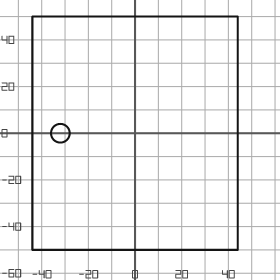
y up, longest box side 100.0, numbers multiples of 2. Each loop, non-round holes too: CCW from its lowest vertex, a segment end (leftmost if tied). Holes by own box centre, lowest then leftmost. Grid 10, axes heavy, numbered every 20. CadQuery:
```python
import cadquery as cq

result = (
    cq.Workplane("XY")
    .moveTo(-44.0, -50.0)
    .lineTo(44.0, -50.0)
    .lineTo(44.0, 50.0)
    .lineTo(-44.0, 50.0)
    .close()
    .moveTo(-32.0, 0.0)
    .circle(4.0)
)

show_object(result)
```